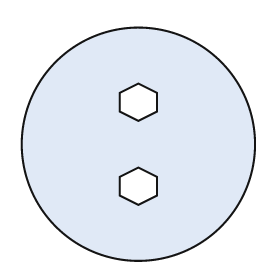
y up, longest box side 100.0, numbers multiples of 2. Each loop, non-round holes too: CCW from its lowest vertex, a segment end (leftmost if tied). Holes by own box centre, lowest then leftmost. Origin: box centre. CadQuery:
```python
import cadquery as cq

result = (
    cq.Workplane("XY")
    .moveTo(0.0, 0.0)
    .circle(50.0)
    .moveTo(0.0, -26.0)
    .lineTo(8.0, -22.0)
    .lineTo(8.0, -14.0)
    .lineTo(0.0, -10.0)
    .lineTo(-8.0, -14.0)
    .lineTo(-8.0, -22.0)
    .close()
    .moveTo(0.0, 10.0)
    .lineTo(8.0, 14.0)
    .lineTo(8.0, 22.0)
    .lineTo(0.0, 26.0)
    .lineTo(-8.0, 22.0)
    .lineTo(-8.0, 14.0)
    .close()
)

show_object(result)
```